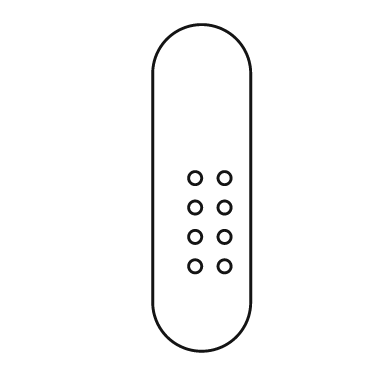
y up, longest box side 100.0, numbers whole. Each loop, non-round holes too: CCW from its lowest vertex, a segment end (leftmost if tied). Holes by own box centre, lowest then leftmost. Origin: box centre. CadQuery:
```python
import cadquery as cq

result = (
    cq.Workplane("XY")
    .moveTo(-15.0, -35.0)
    .threePointArc((0.0, -50.0), (15.0, -35.0))
    .lineTo(15.0, 35.0)
    .threePointArc((0.0, 50.0), (-15.0, 35.0))
    .close()
    .moveTo(-2.0, -24.0)
    .circle(2.0)
    .moveTo(7.0, -24.0)
    .circle(2.0)
    .moveTo(-2.0, -15.0)
    .circle(2.0)
    .moveTo(7.0, -15.0)
    .circle(2.0)
    .moveTo(-2.0, -6.0)
    .circle(2.0)
    .moveTo(7.0, -6.0)
    .circle(2.0)
    .moveTo(-2.0, 3.0)
    .circle(2.0)
    .moveTo(7.0, 3.0)
    .circle(2.0)
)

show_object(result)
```